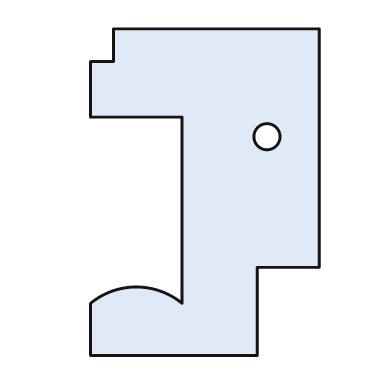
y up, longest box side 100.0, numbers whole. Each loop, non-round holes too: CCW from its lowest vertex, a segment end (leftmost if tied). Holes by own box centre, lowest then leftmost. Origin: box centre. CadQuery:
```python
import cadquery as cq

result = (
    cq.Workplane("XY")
    .moveTo(-35.0, -50.0)
    .lineTo(16.0, -50.0)
    .lineTo(16.0, -23.0)
    .lineTo(35.0, -23.0)
    .lineTo(35.0, 50.0)
    .lineTo(-28.0, 50.0)
    .lineTo(-28.0, 40.0)
    .lineTo(-35.0, 40.0)
    .lineTo(-35.0, 23.0)
    .lineTo(-7.0, 23.0)
    .lineTo(-7.0, -34.0)
    .threePointArc((-21.0, -29.0), (-35.0, -34.0))
    .close()
    .moveTo(19.0, 17.0)
    .circle(4.0)
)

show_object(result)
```